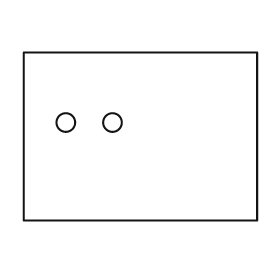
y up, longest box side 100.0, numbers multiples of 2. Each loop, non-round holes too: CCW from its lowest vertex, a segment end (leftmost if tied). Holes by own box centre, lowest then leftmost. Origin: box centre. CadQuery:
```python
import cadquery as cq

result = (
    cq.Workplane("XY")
    .moveTo(-50.0, -36.0)
    .lineTo(50.0, -36.0)
    .lineTo(50.0, 36.0)
    .lineTo(-50.0, 36.0)
    .close()
    .moveTo(-32.0, 6.0)
    .circle(4.0)
    .moveTo(-12.0, 6.0)
    .circle(4.0)
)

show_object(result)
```